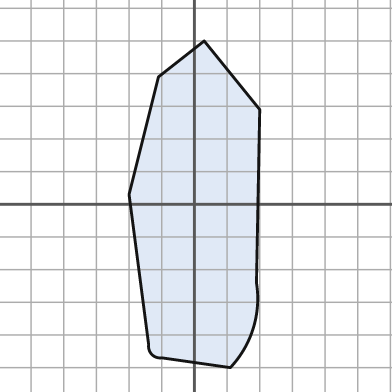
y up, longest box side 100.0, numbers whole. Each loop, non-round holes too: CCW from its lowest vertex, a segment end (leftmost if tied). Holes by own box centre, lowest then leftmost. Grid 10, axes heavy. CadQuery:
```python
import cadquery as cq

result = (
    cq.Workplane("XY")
    .moveTo(11.0, -50.0)
    .threePointArc((18.0, -38.0), (19.0, -24.0))
    .lineTo(20.0, 29.0)
    .lineTo(3.0, 50.0)
    .lineTo(-11.0, 39.0)
    .lineTo(-20.0, 3.0)
    .lineTo(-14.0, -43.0)
    .threePointArc((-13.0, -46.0), (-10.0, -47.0))
    .close()
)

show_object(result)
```